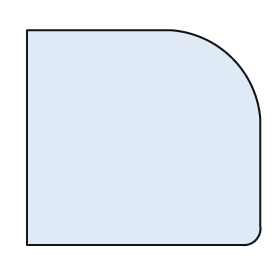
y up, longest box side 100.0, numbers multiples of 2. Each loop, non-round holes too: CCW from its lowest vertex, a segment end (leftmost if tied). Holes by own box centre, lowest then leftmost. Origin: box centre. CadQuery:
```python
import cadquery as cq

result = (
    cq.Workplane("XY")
    .moveTo(-50.0, -46.0)
    .lineTo(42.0, -46.0)
    .threePointArc((48.0, -44.0), (50.0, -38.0))
    .lineTo(50.0, 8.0)
    .threePointArc((38.0, 34.0), (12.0, 46.0))
    .lineTo(-50.0, 46.0)
    .close()
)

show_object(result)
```